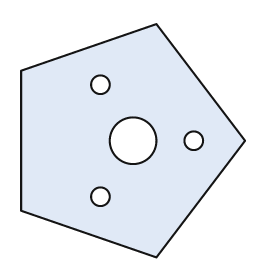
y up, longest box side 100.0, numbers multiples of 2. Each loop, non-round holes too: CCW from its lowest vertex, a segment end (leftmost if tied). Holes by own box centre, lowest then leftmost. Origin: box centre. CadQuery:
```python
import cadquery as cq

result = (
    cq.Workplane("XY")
    .moveTo(10.0, -50.0)
    .lineTo(48.0, 0.0)
    .lineTo(10.0, 50.0)
    .lineTo(-48.0, 30.0)
    .lineTo(-48.0, -30.0)
    .close()
    .moveTo(-14.0, -24.0)
    .circle(4.0)
    .moveTo(0.0, 0.0)
    .circle(10.0)
    .moveTo(26.0, 0.0)
    .circle(4.0)
    .moveTo(-14.0, 24.0)
    .circle(4.0)
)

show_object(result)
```